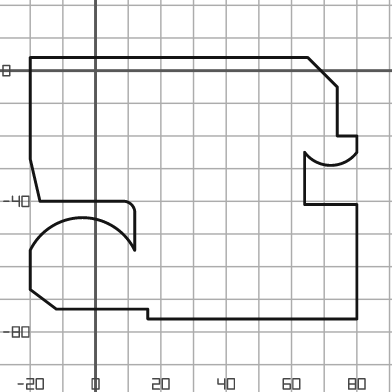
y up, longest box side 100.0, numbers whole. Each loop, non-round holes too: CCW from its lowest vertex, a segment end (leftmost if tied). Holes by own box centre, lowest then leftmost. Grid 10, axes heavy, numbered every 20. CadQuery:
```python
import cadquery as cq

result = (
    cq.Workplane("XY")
    .moveTo(16.0, -76.0)
    .lineTo(80.0, -76.0)
    .lineTo(80.0, -41.0)
    .lineTo(64.0, -41.0)
    .lineTo(64.0, -25.0)
    .threePointArc((72.0, -29.0), (80.0, -25.0))
    .lineTo(80.0, -20.0)
    .lineTo(74.0, -20.0)
    .lineTo(74.0, -5.0)
    .lineTo(65.0, 4.0)
    .lineTo(-20.0, 4.0)
    .lineTo(-20.0, -27.0)
    .lineTo(-17.0, -40.0)
    .lineTo(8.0, -40.0)
    .threePointArc((11.0, -41.0), (12.0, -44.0))
    .lineTo(12.0, -55.0)
    .threePointArc((-4.0, -45.0), (-20.0, -55.0))
    .lineTo(-20.0, -67.0)
    .lineTo(-12.0, -73.0)
    .lineTo(16.0, -73.0)
    .close()
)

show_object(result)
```